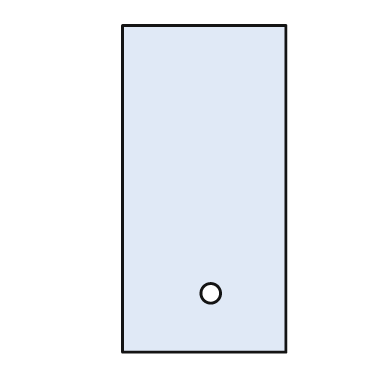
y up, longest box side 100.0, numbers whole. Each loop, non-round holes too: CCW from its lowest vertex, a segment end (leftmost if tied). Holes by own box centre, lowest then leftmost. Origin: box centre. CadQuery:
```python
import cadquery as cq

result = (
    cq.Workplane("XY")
    .moveTo(-25.0, -50.0)
    .lineTo(25.0, -50.0)
    .lineTo(25.0, 50.0)
    .lineTo(-25.0, 50.0)
    .close()
    .moveTo(2.0, -32.0)
    .circle(3.0)
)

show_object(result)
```